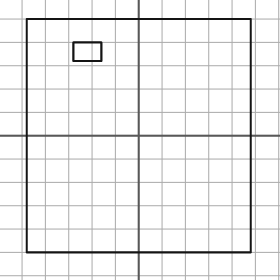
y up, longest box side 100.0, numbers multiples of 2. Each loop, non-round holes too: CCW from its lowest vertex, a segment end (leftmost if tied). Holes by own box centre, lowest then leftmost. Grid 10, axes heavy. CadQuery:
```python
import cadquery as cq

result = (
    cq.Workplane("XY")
    .moveTo(-48.0, -50.0)
    .lineTo(48.0, -50.0)
    .lineTo(48.0, 50.0)
    .lineTo(-48.0, 50.0)
    .close()
    .moveTo(-28.0, 32.0)
    .lineTo(-16.0, 32.0)
    .lineTo(-16.0, 40.0)
    .lineTo(-28.0, 40.0)
    .close()
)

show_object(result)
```